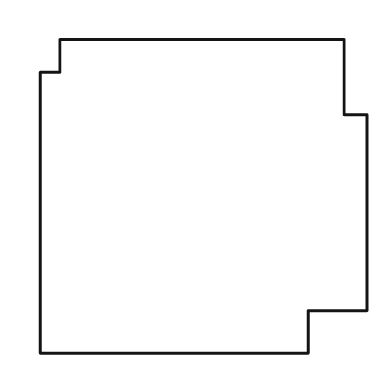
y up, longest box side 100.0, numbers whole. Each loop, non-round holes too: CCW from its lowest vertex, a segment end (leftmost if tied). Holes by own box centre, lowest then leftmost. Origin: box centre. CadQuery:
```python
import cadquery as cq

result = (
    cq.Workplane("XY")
    .moveTo(-50.0, -48.0)
    .lineTo(32.0, -48.0)
    .lineTo(32.0, -35.0)
    .lineTo(50.0, -35.0)
    .lineTo(50.0, 25.0)
    .lineTo(43.0, 25.0)
    .lineTo(43.0, 48.0)
    .lineTo(-44.0, 48.0)
    .lineTo(-44.0, 38.0)
    .lineTo(-50.0, 38.0)
    .close()
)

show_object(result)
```